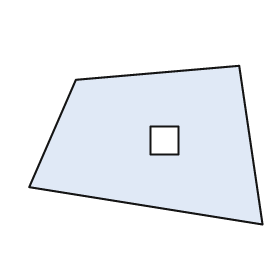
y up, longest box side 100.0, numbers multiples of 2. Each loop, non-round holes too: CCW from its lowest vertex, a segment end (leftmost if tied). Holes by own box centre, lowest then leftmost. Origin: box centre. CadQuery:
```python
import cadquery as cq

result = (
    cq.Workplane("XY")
    .moveTo(50.0, -34.0)
    .lineTo(40.0, 34.0)
    .lineTo(-30.0, 28.0)
    .lineTo(-50.0, -18.0)
    .close()
    .moveTo(2.0, -4.0)
    .lineTo(14.0, -4.0)
    .lineTo(14.0, 8.0)
    .lineTo(2.0, 8.0)
    .close()
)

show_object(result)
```